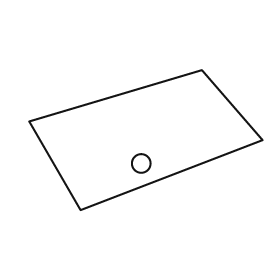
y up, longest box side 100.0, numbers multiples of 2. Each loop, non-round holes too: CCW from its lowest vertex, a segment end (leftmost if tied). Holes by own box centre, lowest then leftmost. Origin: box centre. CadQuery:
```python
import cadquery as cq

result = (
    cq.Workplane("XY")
    .moveTo(-28.0, -30.0)
    .lineTo(50.0, 0.0)
    .lineTo(24.0, 30.0)
    .lineTo(-50.0, 8.0)
    .close()
    .moveTo(-2.0, -10.0)
    .circle(4.0)
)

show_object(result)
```